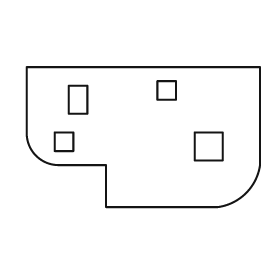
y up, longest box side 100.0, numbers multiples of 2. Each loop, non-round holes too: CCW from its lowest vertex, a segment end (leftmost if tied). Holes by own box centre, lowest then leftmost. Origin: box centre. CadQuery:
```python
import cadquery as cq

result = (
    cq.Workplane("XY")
    .moveTo(-16.0, -30.0)
    .lineTo(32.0, -30.0)
    .threePointArc((44.0, -24.0), (50.0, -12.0))
    .lineTo(50.0, 30.0)
    .lineTo(-50.0, 30.0)
    .lineTo(-50.0, 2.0)
    .threePointArc((-46.0, -8.0), (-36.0, -12.0))
    .lineTo(-16.0, -12.0)
    .close()
    .moveTo(22.0, -10.0)
    .lineTo(34.0, -10.0)
    .lineTo(34.0, 2.0)
    .lineTo(22.0, 2.0)
    .close()
    .moveTo(-38.0, -6.0)
    .lineTo(-30.0, -6.0)
    .lineTo(-30.0, 2.0)
    .lineTo(-38.0, 2.0)
    .close()
    .moveTo(-32.0, 10.0)
    .lineTo(-24.0, 10.0)
    .lineTo(-24.0, 22.0)
    .lineTo(-32.0, 22.0)
    .close()
    .moveTo(6.0, 16.0)
    .lineTo(14.0, 16.0)
    .lineTo(14.0, 24.0)
    .lineTo(6.0, 24.0)
    .close()
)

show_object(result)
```